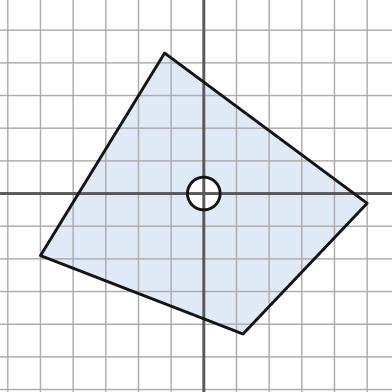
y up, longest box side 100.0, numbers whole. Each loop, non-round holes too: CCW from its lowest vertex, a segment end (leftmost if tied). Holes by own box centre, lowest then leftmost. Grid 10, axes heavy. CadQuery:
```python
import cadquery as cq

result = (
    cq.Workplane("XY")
    .moveTo(12.0, -43.0)
    .lineTo(50.0, -3.0)
    .lineTo(-12.0, 43.0)
    .lineTo(-50.0, -19.0)
    .close()
    .moveTo(0.0, 0.0)
    .circle(5.0)
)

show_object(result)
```